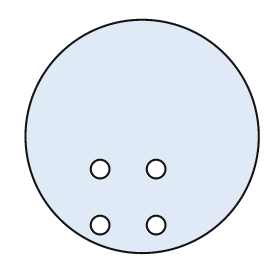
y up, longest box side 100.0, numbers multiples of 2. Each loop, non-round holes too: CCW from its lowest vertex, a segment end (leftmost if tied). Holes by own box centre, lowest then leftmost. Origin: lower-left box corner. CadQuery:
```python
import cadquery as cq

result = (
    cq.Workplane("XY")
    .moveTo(50.0, 50.0)
    .circle(50.0)
    .moveTo(32.0, 12.0)
    .circle(4.0)
    .moveTo(56.0, 12.0)
    .circle(4.0)
    .moveTo(32.0, 36.0)
    .circle(4.0)
    .moveTo(56.0, 36.0)
    .circle(4.0)
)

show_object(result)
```